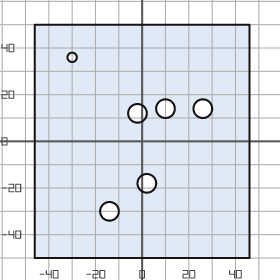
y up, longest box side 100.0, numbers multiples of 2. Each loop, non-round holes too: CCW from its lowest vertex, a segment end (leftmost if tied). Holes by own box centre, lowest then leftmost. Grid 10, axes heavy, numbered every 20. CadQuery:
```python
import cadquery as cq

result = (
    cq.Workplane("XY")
    .moveTo(-46.0, -50.0)
    .lineTo(46.0, -50.0)
    .lineTo(46.0, 50.0)
    .lineTo(-46.0, 50.0)
    .close()
    .moveTo(-14.0, -30.0)
    .circle(4.0)
    .moveTo(2.0, -18.0)
    .circle(4.0)
    .moveTo(-2.0, 12.0)
    .circle(4.0)
    .moveTo(10.0, 14.0)
    .circle(4.0)
    .moveTo(26.0, 14.0)
    .circle(4.0)
    .moveTo(-30.0, 36.0)
    .circle(2.0)
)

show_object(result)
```